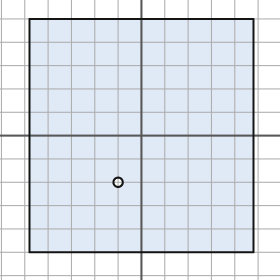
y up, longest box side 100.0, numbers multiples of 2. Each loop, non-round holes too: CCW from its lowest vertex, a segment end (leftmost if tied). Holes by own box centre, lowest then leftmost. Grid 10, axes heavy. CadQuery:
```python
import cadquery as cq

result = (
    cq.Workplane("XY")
    .moveTo(-48.0, -50.0)
    .lineTo(48.0, -50.0)
    .lineTo(48.0, 50.0)
    .lineTo(-48.0, 50.0)
    .close()
    .moveTo(-10.0, -20.0)
    .circle(2.0)
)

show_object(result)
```